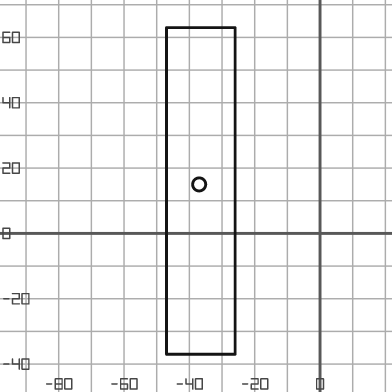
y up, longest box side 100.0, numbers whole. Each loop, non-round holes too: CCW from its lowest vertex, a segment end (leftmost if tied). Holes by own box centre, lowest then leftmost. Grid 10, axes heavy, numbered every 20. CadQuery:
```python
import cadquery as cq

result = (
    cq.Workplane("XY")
    .moveTo(-47.0, -37.0)
    .lineTo(-26.0, -37.0)
    .lineTo(-26.0, 63.0)
    .lineTo(-47.0, 63.0)
    .close()
    .moveTo(-37.0, 15.0)
    .circle(2.0)
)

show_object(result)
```